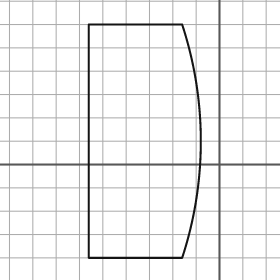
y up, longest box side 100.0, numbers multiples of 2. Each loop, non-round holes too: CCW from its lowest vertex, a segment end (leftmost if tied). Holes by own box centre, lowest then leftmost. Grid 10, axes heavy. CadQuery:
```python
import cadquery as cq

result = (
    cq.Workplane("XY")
    .moveTo(-56.0, -40.0)
    .lineTo(-16.0, -40.0)
    .threePointArc((-8.0, 10.0), (-16.0, 60.0))
    .lineTo(-56.0, 60.0)
    .close()
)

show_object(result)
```